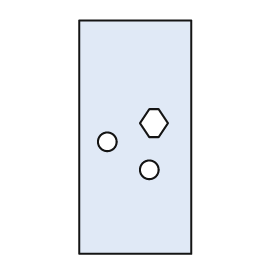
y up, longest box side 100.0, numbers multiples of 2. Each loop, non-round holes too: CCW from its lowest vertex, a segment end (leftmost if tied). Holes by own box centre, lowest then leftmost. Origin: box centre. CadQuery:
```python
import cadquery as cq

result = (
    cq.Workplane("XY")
    .moveTo(-24.0, -50.0)
    .lineTo(24.0, -50.0)
    .lineTo(24.0, 50.0)
    .lineTo(-24.0, 50.0)
    .close()
    .moveTo(6.0, -14.0)
    .circle(4.0)
    .moveTo(-12.0, -2.0)
    .circle(4.0)
    .moveTo(6.0, 0.0)
    .lineTo(10.0, 0.0)
    .lineTo(14.0, 6.0)
    .lineTo(10.0, 12.0)
    .lineTo(6.0, 12.0)
    .lineTo(2.0, 6.0)
    .close()
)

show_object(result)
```